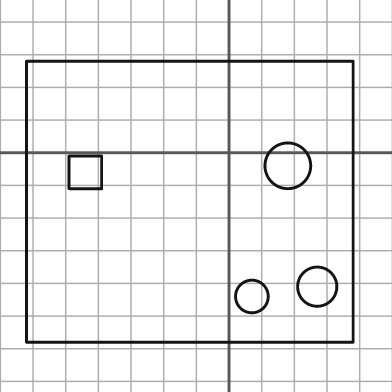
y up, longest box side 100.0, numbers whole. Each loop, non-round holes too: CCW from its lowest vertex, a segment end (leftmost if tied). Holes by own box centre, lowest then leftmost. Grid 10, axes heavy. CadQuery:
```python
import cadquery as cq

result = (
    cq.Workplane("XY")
    .moveTo(-62.0, -58.0)
    .lineTo(38.0, -58.0)
    .lineTo(38.0, 28.0)
    .lineTo(-62.0, 28.0)
    .close()
    .moveTo(7.0, -44.0)
    .circle(5.0)
    .moveTo(27.0, -41.0)
    .circle(6.0)
    .moveTo(-49.0, -11.0)
    .lineTo(-39.0, -11.0)
    .lineTo(-39.0, -1.0)
    .lineTo(-49.0, -1.0)
    .close()
    .moveTo(18.0, -4.0)
    .circle(7.0)
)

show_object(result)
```